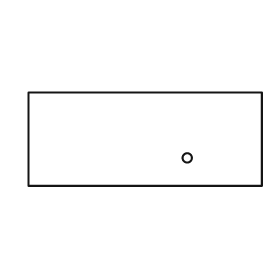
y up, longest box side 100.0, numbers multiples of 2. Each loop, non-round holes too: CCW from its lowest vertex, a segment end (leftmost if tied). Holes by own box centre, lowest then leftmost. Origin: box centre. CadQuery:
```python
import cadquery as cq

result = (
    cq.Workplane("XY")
    .moveTo(-50.0, -20.0)
    .lineTo(50.0, -20.0)
    .lineTo(50.0, 20.0)
    .lineTo(-50.0, 20.0)
    .close()
    .moveTo(18.0, -8.0)
    .circle(2.0)
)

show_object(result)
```